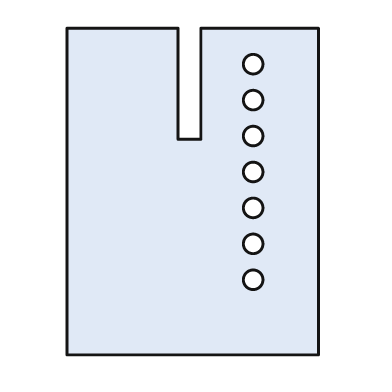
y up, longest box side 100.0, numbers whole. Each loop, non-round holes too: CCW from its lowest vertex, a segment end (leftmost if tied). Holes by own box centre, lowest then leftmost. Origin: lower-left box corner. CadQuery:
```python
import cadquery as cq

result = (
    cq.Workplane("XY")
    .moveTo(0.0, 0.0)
    .lineTo(77.0, 0.0)
    .lineTo(77.0, 100.0)
    .lineTo(41.0, 100.0)
    .lineTo(41.0, 66.0)
    .lineTo(34.0, 66.0)
    .lineTo(34.0, 100.0)
    .lineTo(0.0, 100.0)
    .close()
    .moveTo(57.0, 23.0)
    .circle(3.0)
    .moveTo(57.0, 34.0)
    .circle(3.0)
    .moveTo(57.0, 45.0)
    .circle(3.0)
    .moveTo(57.0, 56.0)
    .circle(3.0)
    .moveTo(57.0, 67.0)
    .circle(3.0)
    .moveTo(57.0, 78.0)
    .circle(3.0)
    .moveTo(57.0, 89.0)
    .circle(3.0)
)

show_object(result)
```